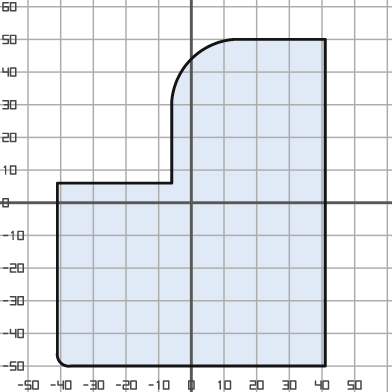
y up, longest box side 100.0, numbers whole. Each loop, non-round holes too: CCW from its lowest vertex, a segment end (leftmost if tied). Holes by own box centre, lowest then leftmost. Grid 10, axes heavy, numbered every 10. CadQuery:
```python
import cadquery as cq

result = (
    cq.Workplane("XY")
    .moveTo(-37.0, -50.0)
    .lineTo(41.0, -50.0)
    .lineTo(41.0, 50.0)
    .lineTo(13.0, 50.0)
    .threePointArc((0.0, 44.0), (-6.0, 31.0))
    .lineTo(-6.0, 6.0)
    .lineTo(-41.0, 6.0)
    .lineTo(-41.0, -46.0)
    .threePointArc((-40.0, -49.0), (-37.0, -50.0))
    .close()
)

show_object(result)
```